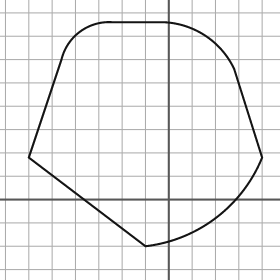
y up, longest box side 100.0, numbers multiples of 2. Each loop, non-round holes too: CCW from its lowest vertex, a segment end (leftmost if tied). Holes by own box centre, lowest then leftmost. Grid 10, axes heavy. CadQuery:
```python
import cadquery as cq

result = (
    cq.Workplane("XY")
    .moveTo(-10.0, -20.0)
    .threePointArc((20.0, -8.0), (40.0, 18.0))
    .lineTo(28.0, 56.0)
    .threePointArc((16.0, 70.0), (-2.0, 76.0))
    .lineTo(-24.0, 76.0)
    .threePointArc((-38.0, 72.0), (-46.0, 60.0))
    .lineTo(-60.0, 18.0)
    .close()
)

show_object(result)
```